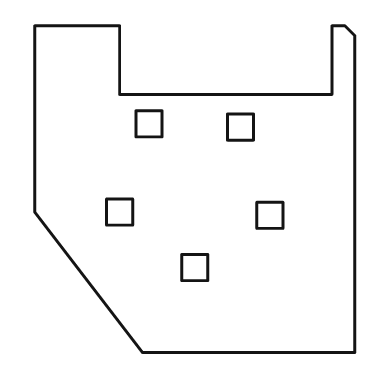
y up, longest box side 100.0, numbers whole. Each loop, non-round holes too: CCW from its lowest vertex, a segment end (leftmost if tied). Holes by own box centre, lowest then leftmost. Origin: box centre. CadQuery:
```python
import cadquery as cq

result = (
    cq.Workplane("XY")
    .moveTo(-16.0, -50.0)
    .lineTo(49.0, -50.0)
    .lineTo(49.0, 47.0)
    .lineTo(46.0, 50.0)
    .lineTo(42.0, 50.0)
    .lineTo(42.0, 29.0)
    .lineTo(-23.0, 29.0)
    .lineTo(-23.0, 50.0)
    .lineTo(-49.0, 50.0)
    .lineTo(-49.0, -7.0)
    .close()
    .moveTo(-4.0, -28.0)
    .lineTo(4.0, -28.0)
    .lineTo(4.0, -20.0)
    .lineTo(-4.0, -20.0)
    .close()
    .moveTo(19.0, -12.0)
    .lineTo(27.0, -12.0)
    .lineTo(27.0, -4.0)
    .lineTo(19.0, -4.0)
    .close()
    .moveTo(-27.0, -11.0)
    .lineTo(-19.0, -11.0)
    .lineTo(-19.0, -3.0)
    .lineTo(-27.0, -3.0)
    .close()
    .moveTo(10.0, 15.0)
    .lineTo(18.0, 15.0)
    .lineTo(18.0, 23.0)
    .lineTo(10.0, 23.0)
    .close()
    .moveTo(-18.0, 16.0)
    .lineTo(-10.0, 16.0)
    .lineTo(-10.0, 24.0)
    .lineTo(-18.0, 24.0)
    .close()
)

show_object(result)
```